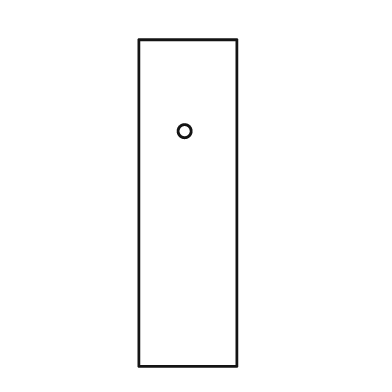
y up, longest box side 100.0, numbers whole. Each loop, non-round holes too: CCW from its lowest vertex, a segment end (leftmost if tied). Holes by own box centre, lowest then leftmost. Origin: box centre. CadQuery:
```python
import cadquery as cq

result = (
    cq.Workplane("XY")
    .moveTo(-15.0, -50.0)
    .lineTo(15.0, -50.0)
    .lineTo(15.0, 50.0)
    .lineTo(-15.0, 50.0)
    .close()
    .moveTo(-1.0, 22.0)
    .circle(2.0)
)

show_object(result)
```